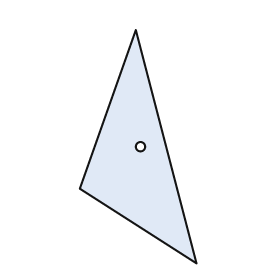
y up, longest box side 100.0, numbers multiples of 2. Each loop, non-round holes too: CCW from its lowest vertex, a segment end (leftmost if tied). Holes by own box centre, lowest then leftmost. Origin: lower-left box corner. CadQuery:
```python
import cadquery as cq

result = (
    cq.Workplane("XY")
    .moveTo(50.0, 0.0)
    .lineTo(24.0, 100.0)
    .lineTo(0.0, 32.0)
    .close()
    .moveTo(26.0, 50.0)
    .circle(2.0)
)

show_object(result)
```